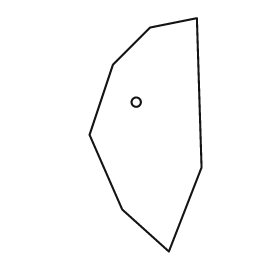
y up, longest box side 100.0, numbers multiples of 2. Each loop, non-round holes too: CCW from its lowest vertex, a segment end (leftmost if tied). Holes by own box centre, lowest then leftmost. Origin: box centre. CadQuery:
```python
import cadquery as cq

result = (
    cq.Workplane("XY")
    .moveTo(10.0, -50.0)
    .lineTo(24.0, -14.0)
    .lineTo(22.0, 50.0)
    .lineTo(2.0, 46.0)
    .lineTo(-14.0, 30.0)
    .lineTo(-24.0, 0.0)
    .lineTo(-10.0, -32.0)
    .close()
    .moveTo(-4.0, 14.0)
    .circle(2.0)
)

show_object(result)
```